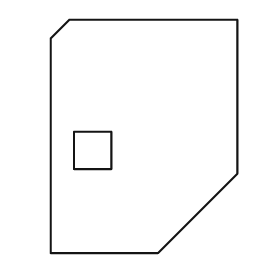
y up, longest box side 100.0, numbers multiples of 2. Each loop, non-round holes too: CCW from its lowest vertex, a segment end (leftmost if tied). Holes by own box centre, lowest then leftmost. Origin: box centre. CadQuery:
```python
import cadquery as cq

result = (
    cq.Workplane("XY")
    .moveTo(-40.0, -50.0)
    .lineTo(6.0, -50.0)
    .lineTo(40.0, -16.0)
    .lineTo(40.0, 50.0)
    .lineTo(-32.0, 50.0)
    .lineTo(-40.0, 42.0)
    .close()
    .moveTo(-30.0, -14.0)
    .lineTo(-14.0, -14.0)
    .lineTo(-14.0, 2.0)
    .lineTo(-30.0, 2.0)
    .close()
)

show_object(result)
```